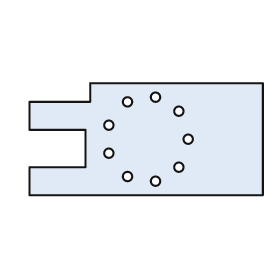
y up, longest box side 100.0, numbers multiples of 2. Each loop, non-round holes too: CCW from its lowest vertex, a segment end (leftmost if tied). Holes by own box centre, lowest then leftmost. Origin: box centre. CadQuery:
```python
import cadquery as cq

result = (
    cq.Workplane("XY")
    .moveTo(-50.0, -24.0)
    .lineTo(50.0, -24.0)
    .lineTo(50.0, 24.0)
    .lineTo(-24.0, 24.0)
    .lineTo(-24.0, 16.0)
    .lineTo(-50.0, 16.0)
    .lineTo(-50.0, 4.0)
    .lineTo(-26.0, 4.0)
    .lineTo(-26.0, -12.0)
    .lineTo(-50.0, -12.0)
    .close()
    .moveTo(4.0, -18.0)
    .circle(2.0)
    .moveTo(-8.0, -16.0)
    .circle(2.0)
    .moveTo(14.0, -12.0)
    .circle(2.0)
    .moveTo(-16.0, -6.0)
    .circle(2.0)
    .moveTo(18.0, 0.0)
    .circle(2.0)
    .moveTo(-16.0, 6.0)
    .circle(2.0)
    .moveTo(14.0, 12.0)
    .circle(2.0)
    .moveTo(-8.0, 16.0)
    .circle(2.0)
    .moveTo(4.0, 18.0)
    .circle(2.0)
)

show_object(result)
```